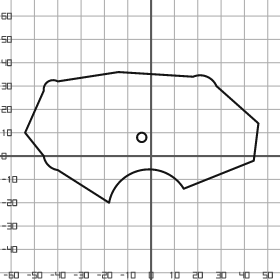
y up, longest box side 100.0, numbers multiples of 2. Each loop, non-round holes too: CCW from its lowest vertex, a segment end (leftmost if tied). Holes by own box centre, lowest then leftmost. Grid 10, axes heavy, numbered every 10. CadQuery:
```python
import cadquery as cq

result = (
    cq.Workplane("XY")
    .moveTo(-18.0, -20.0)
    .threePointArc((-4.0, -6.0), (14.0, -14.0))
    .lineTo(44.0, -2.0)
    .lineTo(46.0, 14.0)
    .lineTo(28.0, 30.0)
    .threePointArc((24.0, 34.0), (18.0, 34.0))
    .lineTo(-14.0, 36.0)
    .lineTo(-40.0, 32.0)
    .threePointArc((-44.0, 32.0), (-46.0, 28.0))
    .lineTo(-54.0, 10.0)
    .lineTo(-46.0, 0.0)
    .threePointArc((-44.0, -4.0), (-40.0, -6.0))
    .close()
    .moveTo(-4.0, 8.0)
    .circle(2.0)
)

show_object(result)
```